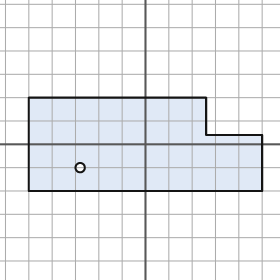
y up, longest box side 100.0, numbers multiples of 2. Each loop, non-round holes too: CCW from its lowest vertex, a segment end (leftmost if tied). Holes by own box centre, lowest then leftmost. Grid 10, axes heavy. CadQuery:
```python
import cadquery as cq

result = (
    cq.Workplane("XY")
    .moveTo(-50.0, -20.0)
    .lineTo(50.0, -20.0)
    .lineTo(50.0, 4.0)
    .lineTo(26.0, 4.0)
    .lineTo(26.0, 20.0)
    .lineTo(-50.0, 20.0)
    .close()
    .moveTo(-28.0, -10.0)
    .circle(2.0)
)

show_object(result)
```